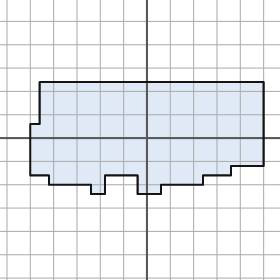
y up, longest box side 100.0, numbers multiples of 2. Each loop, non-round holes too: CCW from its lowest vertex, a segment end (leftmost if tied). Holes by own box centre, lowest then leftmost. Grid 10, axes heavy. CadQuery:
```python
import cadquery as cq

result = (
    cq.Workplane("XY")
    .moveTo(-24.0, -24.0)
    .lineTo(-18.0, -24.0)
    .lineTo(-18.0, -16.0)
    .lineTo(-4.0, -16.0)
    .lineTo(-4.0, -24.0)
    .lineTo(6.0, -24.0)
    .lineTo(6.0, -20.0)
    .lineTo(24.0, -20.0)
    .lineTo(24.0, -16.0)
    .lineTo(36.0, -16.0)
    .lineTo(36.0, -12.0)
    .lineTo(50.0, -12.0)
    .lineTo(50.0, 24.0)
    .lineTo(-46.0, 24.0)
    .lineTo(-46.0, 6.0)
    .lineTo(-50.0, 6.0)
    .lineTo(-50.0, -16.0)
    .lineTo(-42.0, -16.0)
    .lineTo(-42.0, -20.0)
    .lineTo(-24.0, -20.0)
    .close()
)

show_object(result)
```